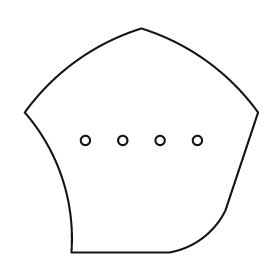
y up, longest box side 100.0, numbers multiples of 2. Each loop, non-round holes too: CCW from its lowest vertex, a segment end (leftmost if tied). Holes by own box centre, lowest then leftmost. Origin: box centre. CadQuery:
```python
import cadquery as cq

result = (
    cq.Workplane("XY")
    .moveTo(-30.0, -48.0)
    .lineTo(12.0, -48.0)
    .threePointArc((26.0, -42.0), (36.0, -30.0))
    .lineTo(50.0, 12.0)
    .threePointArc((28.0, 34.0), (0.0, 48.0))
    .threePointArc((-28.0, 34.0), (-50.0, 12.0))
    .threePointArc((-34.0, -16.0), (-30.0, -48.0))
    .close()
    .moveTo(-24.0, 0.0)
    .circle(2.0)
    .moveTo(-8.0, 0.0)
    .circle(2.0)
    .moveTo(8.0, 0.0)
    .circle(2.0)
    .moveTo(24.0, 0.0)
    .circle(2.0)
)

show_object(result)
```